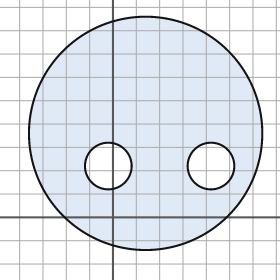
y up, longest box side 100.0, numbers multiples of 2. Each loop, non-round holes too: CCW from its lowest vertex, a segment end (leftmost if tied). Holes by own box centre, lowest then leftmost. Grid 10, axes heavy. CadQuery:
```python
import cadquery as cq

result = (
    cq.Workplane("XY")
    .moveTo(14.0, 36.0)
    .circle(50.0)
    .moveTo(-2.0, 22.0)
    .circle(10.0)
    .moveTo(42.0, 22.0)
    .circle(10.0)
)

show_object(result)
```